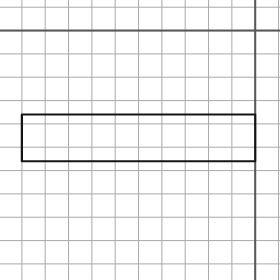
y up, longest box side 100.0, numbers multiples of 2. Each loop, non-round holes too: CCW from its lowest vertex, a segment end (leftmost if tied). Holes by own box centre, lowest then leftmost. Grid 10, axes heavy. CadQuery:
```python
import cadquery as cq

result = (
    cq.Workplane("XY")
    .moveTo(-100.0, -56.0)
    .lineTo(0.0, -56.0)
    .lineTo(0.0, -36.0)
    .lineTo(-100.0, -36.0)
    .close()
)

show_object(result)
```